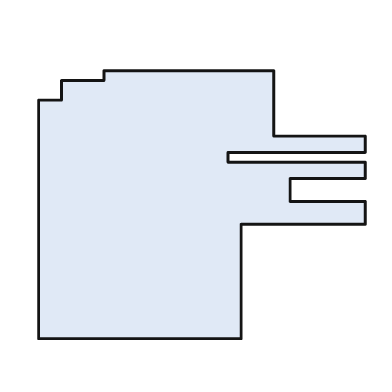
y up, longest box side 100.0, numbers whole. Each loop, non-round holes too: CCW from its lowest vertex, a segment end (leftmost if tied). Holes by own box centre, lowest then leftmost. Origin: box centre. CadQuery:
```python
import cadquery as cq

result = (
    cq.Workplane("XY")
    .moveTo(-50.0, -41.0)
    .lineTo(12.0, -41.0)
    .lineTo(12.0, -6.0)
    .lineTo(50.0, -6.0)
    .lineTo(50.0, 1.0)
    .lineTo(27.0, 1.0)
    .lineTo(27.0, 8.0)
    .lineTo(50.0, 8.0)
    .lineTo(50.0, 13.0)
    .lineTo(8.0, 13.0)
    .lineTo(8.0, 16.0)
    .lineTo(50.0, 16.0)
    .lineTo(50.0, 21.0)
    .lineTo(22.0, 21.0)
    .lineTo(22.0, 41.0)
    .lineTo(-30.0, 41.0)
    .lineTo(-30.0, 38.0)
    .lineTo(-43.0, 38.0)
    .lineTo(-43.0, 32.0)
    .lineTo(-50.0, 32.0)
    .close()
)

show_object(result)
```